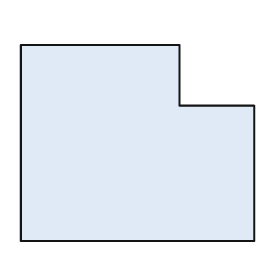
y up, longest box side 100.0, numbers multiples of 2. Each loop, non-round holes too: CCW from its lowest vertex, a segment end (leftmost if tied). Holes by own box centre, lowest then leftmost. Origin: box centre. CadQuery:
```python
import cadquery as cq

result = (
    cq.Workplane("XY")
    .moveTo(-50.0, -42.0)
    .lineTo(50.0, -42.0)
    .lineTo(50.0, 16.0)
    .lineTo(18.0, 16.0)
    .lineTo(18.0, 42.0)
    .lineTo(-50.0, 42.0)
    .close()
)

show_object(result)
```